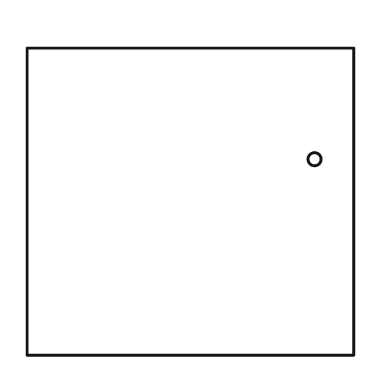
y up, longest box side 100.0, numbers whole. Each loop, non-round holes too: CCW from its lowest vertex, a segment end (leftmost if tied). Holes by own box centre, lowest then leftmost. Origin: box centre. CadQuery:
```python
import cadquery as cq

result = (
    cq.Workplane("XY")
    .moveTo(-50.0, -47.0)
    .lineTo(50.0, -47.0)
    .lineTo(50.0, 47.0)
    .lineTo(-50.0, 47.0)
    .close()
    .moveTo(38.0, 13.0)
    .circle(2.0)
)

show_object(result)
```